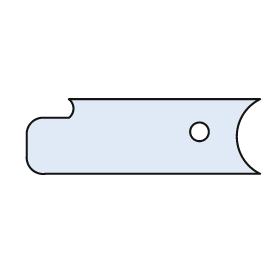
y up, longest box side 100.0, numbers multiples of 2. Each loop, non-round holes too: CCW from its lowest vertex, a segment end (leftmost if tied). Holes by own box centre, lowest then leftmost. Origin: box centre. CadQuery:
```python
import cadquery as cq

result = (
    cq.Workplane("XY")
    .moveTo(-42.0, -16.0)
    .lineTo(50.0, -16.0)
    .threePointArc((40.0, 0.0), (50.0, 16.0))
    .lineTo(-32.0, 16.0)
    .threePointArc((-30.0, 12.0), (-32.0, 8.0))
    .lineTo(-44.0, 8.0)
    .threePointArc((-48.0, 6.0), (-50.0, 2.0))
    .lineTo(-50.0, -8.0)
    .threePointArc((-48.0, -14.0), (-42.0, -16.0))
    .close()
    .moveTo(24.0, 2.0)
    .circle(4.0)
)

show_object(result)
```